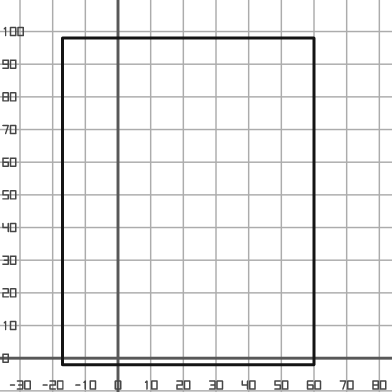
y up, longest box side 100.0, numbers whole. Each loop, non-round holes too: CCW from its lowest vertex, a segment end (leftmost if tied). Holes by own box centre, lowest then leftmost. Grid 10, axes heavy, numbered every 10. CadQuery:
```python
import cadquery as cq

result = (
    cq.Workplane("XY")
    .moveTo(-17.0, -2.0)
    .lineTo(60.0, -2.0)
    .lineTo(60.0, 98.0)
    .lineTo(-17.0, 98.0)
    .close()
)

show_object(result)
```